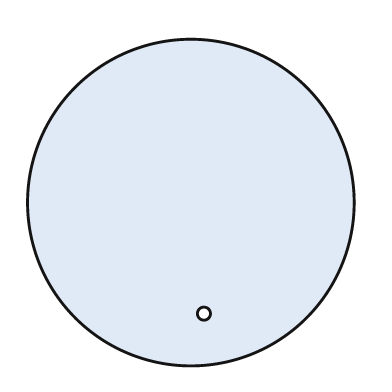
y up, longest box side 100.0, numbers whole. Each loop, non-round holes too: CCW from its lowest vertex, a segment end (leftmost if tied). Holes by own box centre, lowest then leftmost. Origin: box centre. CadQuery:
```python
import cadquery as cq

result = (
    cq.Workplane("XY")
    .moveTo(0.0, 0.0)
    .circle(50.0)
    .moveTo(4.0, -34.0)
    .circle(2.0)
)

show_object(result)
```